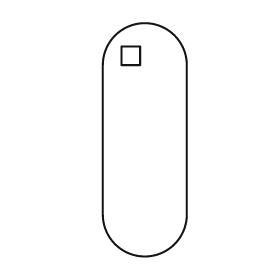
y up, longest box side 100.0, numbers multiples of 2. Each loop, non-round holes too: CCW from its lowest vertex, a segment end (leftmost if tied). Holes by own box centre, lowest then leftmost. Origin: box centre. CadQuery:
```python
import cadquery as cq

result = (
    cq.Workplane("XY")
    .moveTo(-18.0, -32.0)
    .threePointArc((0.0, -50.0), (18.0, -32.0))
    .lineTo(18.0, 32.0)
    .threePointArc((0.0, 50.0), (-18.0, 32.0))
    .close()
    .moveTo(-10.0, 32.0)
    .lineTo(-2.0, 32.0)
    .lineTo(-2.0, 40.0)
    .lineTo(-10.0, 40.0)
    .close()
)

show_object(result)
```